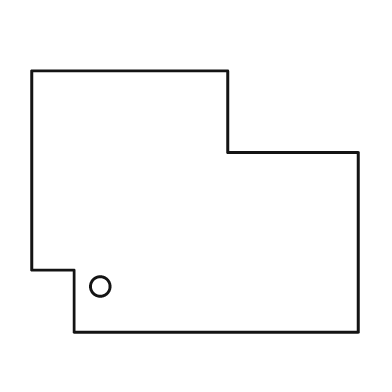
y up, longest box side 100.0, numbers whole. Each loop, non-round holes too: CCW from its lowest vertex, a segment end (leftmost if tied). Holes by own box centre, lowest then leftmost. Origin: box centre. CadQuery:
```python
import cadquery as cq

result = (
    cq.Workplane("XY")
    .moveTo(-37.0, -40.0)
    .lineTo(50.0, -40.0)
    .lineTo(50.0, 15.0)
    .lineTo(10.0, 15.0)
    .lineTo(10.0, 40.0)
    .lineTo(-50.0, 40.0)
    .lineTo(-50.0, -21.0)
    .lineTo(-37.0, -21.0)
    .close()
    .moveTo(-29.0, -26.0)
    .circle(3.0)
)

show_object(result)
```